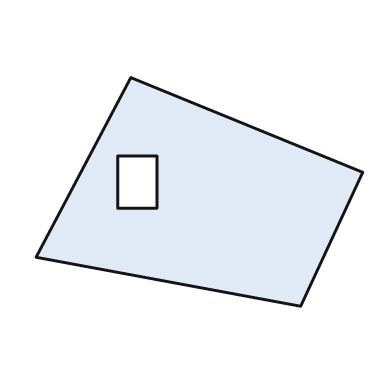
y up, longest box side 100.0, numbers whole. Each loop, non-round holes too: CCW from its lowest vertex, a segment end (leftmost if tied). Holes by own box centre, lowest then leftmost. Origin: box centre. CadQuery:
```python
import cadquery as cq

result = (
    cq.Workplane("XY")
    .moveTo(31.0, -35.0)
    .lineTo(50.0, 6.0)
    .lineTo(-21.0, 35.0)
    .lineTo(-50.0, -20.0)
    .close()
    .moveTo(-25.0, -5.0)
    .lineTo(-13.0, -5.0)
    .lineTo(-13.0, 11.0)
    .lineTo(-25.0, 11.0)
    .close()
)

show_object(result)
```